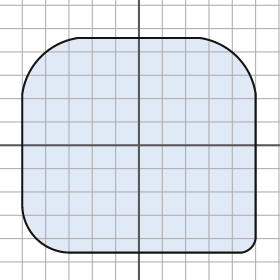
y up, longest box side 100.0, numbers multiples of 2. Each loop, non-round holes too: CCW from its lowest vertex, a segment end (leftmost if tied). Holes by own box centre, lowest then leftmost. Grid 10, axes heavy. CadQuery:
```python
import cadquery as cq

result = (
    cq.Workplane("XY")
    .moveTo(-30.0, -46.0)
    .lineTo(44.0, -46.0)
    .threePointArc((48.0, -44.0), (50.0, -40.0))
    .lineTo(50.0, 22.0)
    .threePointArc((42.0, 38.0), (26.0, 46.0))
    .lineTo(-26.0, 46.0)
    .threePointArc((-42.0, 38.0), (-50.0, 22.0))
    .lineTo(-50.0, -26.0)
    .threePointArc((-44.0, -40.0), (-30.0, -46.0))
    .close()
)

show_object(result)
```